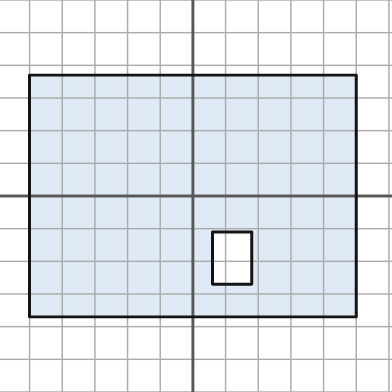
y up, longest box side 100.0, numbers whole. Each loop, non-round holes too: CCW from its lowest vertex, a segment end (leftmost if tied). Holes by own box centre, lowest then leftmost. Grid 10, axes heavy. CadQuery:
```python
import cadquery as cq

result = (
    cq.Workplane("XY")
    .moveTo(-50.0, -37.0)
    .lineTo(50.0, -37.0)
    .lineTo(50.0, 37.0)
    .lineTo(-50.0, 37.0)
    .close()
    .moveTo(6.0, -27.0)
    .lineTo(18.0, -27.0)
    .lineTo(18.0, -11.0)
    .lineTo(6.0, -11.0)
    .close()
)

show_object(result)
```